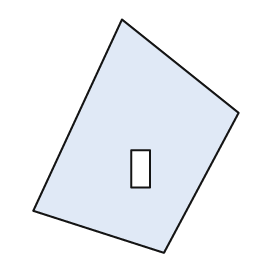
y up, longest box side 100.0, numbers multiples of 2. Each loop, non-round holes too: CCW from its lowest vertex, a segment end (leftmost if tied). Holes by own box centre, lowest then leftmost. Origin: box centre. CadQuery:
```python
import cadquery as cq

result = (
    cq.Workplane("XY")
    .moveTo(12.0, -50.0)
    .lineTo(44.0, 10.0)
    .lineTo(-6.0, 50.0)
    .lineTo(-44.0, -32.0)
    .close()
    .moveTo(-2.0, -22.0)
    .lineTo(6.0, -22.0)
    .lineTo(6.0, -6.0)
    .lineTo(-2.0, -6.0)
    .close()
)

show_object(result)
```